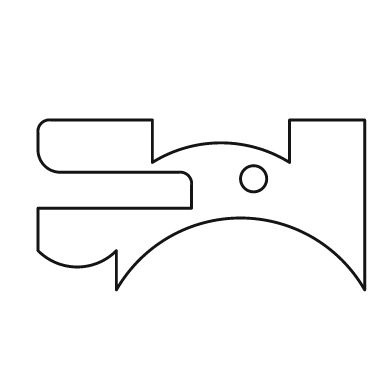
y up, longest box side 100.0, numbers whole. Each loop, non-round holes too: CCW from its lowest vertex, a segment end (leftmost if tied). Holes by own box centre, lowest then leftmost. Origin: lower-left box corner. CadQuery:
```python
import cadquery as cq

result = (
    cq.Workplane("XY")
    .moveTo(24.0, 0.0)
    .threePointArc((62.0, 22.0), (100.0, 0.0))
    .lineTo(100.0, 52.0)
    .lineTo(77.0, 52.0)
    .lineTo(77.0, 39.0)
    .threePointArc((56.0, 45.0), (35.0, 39.0))
    .lineTo(35.0, 52.0)
    .lineTo(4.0, 52.0)
    .threePointArc((1.0, 51.0), (0.0, 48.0))
    .lineTo(0.0, 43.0)
    .threePointArc((2.0, 38.0), (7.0, 36.0))
    .lineTo(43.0, 36.0)
    .threePointArc((46.0, 35.0), (47.0, 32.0))
    .lineTo(47.0, 25.0)
    .lineTo(0.0, 25.0)
    .lineTo(0.0, 12.0)
    .threePointArc((12.0, 7.0), (24.0, 12.0))
    .close()
    .moveTo(66.0, 34.0)
    .circle(4.0)
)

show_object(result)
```